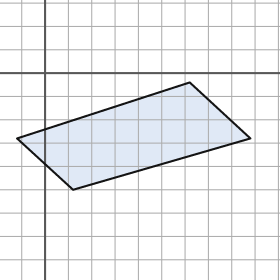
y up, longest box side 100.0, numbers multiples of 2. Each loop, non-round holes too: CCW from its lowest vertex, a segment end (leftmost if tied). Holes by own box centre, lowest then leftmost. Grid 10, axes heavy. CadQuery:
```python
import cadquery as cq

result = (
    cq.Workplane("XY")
    .moveTo(12.0, -50.0)
    .lineTo(88.0, -28.0)
    .lineTo(62.0, -4.0)
    .lineTo(-12.0, -28.0)
    .close()
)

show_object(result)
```